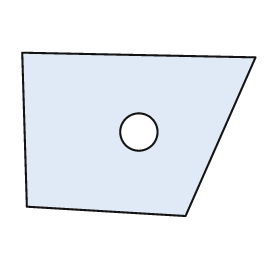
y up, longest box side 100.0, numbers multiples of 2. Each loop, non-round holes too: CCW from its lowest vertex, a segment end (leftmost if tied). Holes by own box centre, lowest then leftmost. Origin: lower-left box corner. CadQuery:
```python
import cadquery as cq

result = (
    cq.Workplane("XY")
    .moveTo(70.0, 0.0)
    .lineTo(100.0, 68.0)
    .lineTo(0.0, 70.0)
    .lineTo(2.0, 4.0)
    .close()
    .moveTo(50.0, 36.0)
    .circle(8.0)
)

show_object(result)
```